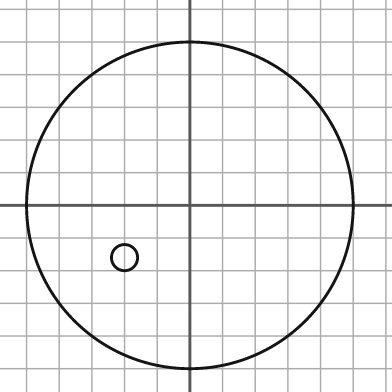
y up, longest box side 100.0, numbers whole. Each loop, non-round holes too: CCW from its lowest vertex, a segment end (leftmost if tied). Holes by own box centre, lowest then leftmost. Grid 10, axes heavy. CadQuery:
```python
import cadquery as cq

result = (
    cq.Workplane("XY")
    .moveTo(0.0, 0.0)
    .circle(50.0)
    .moveTo(-20.0, -16.0)
    .circle(4.0)
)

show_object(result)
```